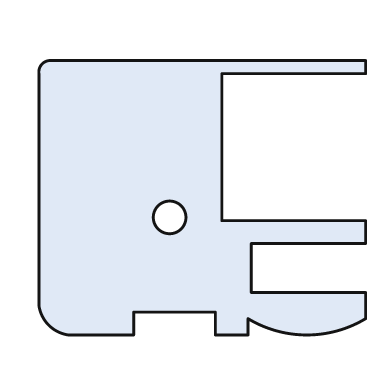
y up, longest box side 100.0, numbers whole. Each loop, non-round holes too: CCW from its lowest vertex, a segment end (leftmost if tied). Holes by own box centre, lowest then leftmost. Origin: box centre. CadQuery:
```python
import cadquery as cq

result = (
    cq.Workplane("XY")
    .moveTo(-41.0, -42.0)
    .lineTo(-21.0, -42.0)
    .lineTo(-21.0, -35.0)
    .lineTo(4.0, -35.0)
    .lineTo(4.0, -42.0)
    .lineTo(14.0, -42.0)
    .lineTo(14.0, -37.0)
    .threePointArc((32.0, -42.0), (50.0, -37.0))
    .lineTo(50.0, -29.0)
    .lineTo(15.0, -29.0)
    .lineTo(15.0, -14.0)
    .lineTo(50.0, -14.0)
    .lineTo(50.0, -7.0)
    .lineTo(6.0, -7.0)
    .lineTo(6.0, 38.0)
    .lineTo(50.0, 38.0)
    .lineTo(50.0, 42.0)
    .lineTo(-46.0, 42.0)
    .threePointArc((-49.0, 41.0), (-50.0, 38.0))
    .lineTo(-50.0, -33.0)
    .threePointArc((-47.0, -39.0), (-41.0, -42.0))
    .close()
    .moveTo(-10.0, -6.0)
    .circle(5.0)
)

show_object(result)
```